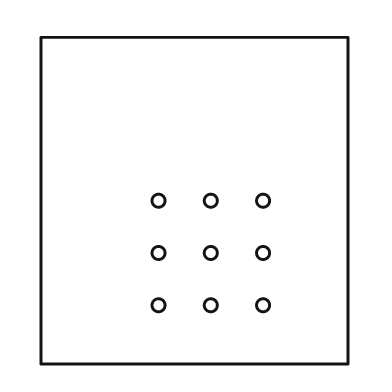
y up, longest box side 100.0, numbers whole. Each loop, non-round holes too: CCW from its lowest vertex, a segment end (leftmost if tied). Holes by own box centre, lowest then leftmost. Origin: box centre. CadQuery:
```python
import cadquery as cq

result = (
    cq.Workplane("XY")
    .moveTo(-47.0, -50.0)
    .lineTo(47.0, -50.0)
    .lineTo(47.0, 50.0)
    .lineTo(-47.0, 50.0)
    .close()
    .moveTo(-11.0, -32.0)
    .circle(2.0)
    .moveTo(5.0, -32.0)
    .circle(2.0)
    .moveTo(21.0, -32.0)
    .circle(2.0)
    .moveTo(-11.0, -16.0)
    .circle(2.0)
    .moveTo(5.0, -16.0)
    .circle(2.0)
    .moveTo(21.0, -16.0)
    .circle(2.0)
    .moveTo(-11.0, 0.0)
    .circle(2.0)
    .moveTo(5.0, 0.0)
    .circle(2.0)
    .moveTo(21.0, 0.0)
    .circle(2.0)
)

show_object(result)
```